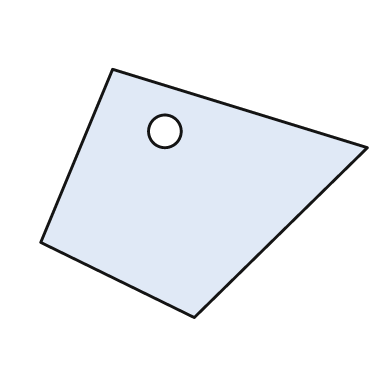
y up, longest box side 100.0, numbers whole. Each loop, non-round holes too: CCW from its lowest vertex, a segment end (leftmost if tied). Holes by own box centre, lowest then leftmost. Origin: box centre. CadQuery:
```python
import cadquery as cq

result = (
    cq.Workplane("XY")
    .moveTo(-3.0, -38.0)
    .lineTo(50.0, 14.0)
    .lineTo(-28.0, 38.0)
    .lineTo(-50.0, -15.0)
    .close()
    .moveTo(-12.0, 19.0)
    .circle(5.0)
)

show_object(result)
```